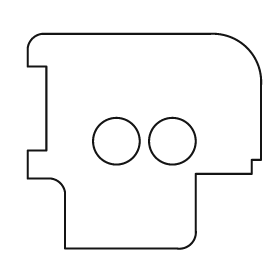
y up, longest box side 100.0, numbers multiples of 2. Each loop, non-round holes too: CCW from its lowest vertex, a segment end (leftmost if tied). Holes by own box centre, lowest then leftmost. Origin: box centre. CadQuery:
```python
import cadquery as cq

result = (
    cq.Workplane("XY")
    .moveTo(-34.0, -46.0)
    .lineTo(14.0, -46.0)
    .threePointArc((20.0, -44.0), (22.0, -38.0))
    .lineTo(22.0, -14.0)
    .lineTo(46.0, -14.0)
    .lineTo(46.0, -8.0)
    .lineTo(50.0, -8.0)
    .lineTo(50.0, 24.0)
    .threePointArc((44.0, 40.0), (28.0, 46.0))
    .lineTo(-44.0, 46.0)
    .threePointArc((-48.0, 44.0), (-50.0, 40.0))
    .lineTo(-50.0, 32.0)
    .lineTo(-42.0, 32.0)
    .lineTo(-42.0, -4.0)
    .lineTo(-50.0, -4.0)
    .lineTo(-50.0, -16.0)
    .lineTo(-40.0, -16.0)
    .threePointArc((-36.0, -18.0), (-34.0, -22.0))
    .close()
    .moveTo(-12.0, 0.0)
    .circle(10.0)
    .moveTo(12.0, 0.0)
    .circle(10.0)
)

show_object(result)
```